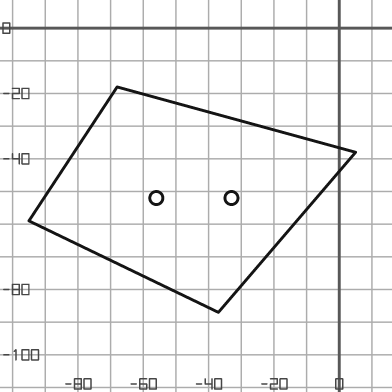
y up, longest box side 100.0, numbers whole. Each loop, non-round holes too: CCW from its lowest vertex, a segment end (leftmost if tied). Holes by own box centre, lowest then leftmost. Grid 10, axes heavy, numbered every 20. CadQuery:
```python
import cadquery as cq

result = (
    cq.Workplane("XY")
    .moveTo(-37.0, -87.0)
    .lineTo(5.0, -38.0)
    .lineTo(-68.0, -18.0)
    .lineTo(-95.0, -59.0)
    .close()
    .moveTo(-56.0, -52.0)
    .circle(2.0)
    .moveTo(-33.0, -52.0)
    .circle(2.0)
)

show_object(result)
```